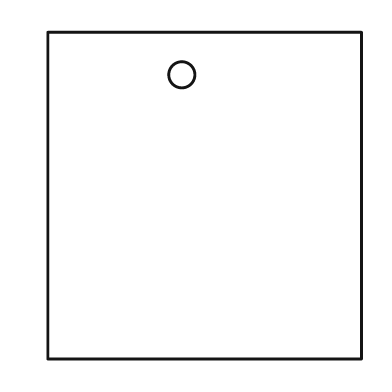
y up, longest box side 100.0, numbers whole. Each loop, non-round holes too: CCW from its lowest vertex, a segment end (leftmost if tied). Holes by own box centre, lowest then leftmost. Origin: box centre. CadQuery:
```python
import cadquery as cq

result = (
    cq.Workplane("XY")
    .moveTo(-48.0, -50.0)
    .lineTo(48.0, -50.0)
    .lineTo(48.0, 50.0)
    .lineTo(-48.0, 50.0)
    .close()
    .moveTo(-7.0, 37.0)
    .circle(4.0)
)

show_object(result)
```